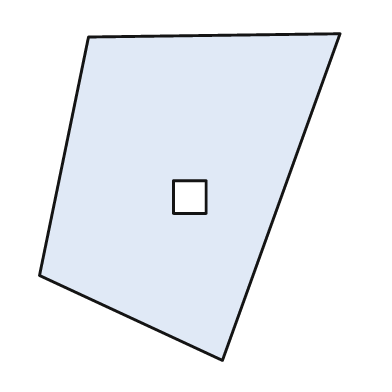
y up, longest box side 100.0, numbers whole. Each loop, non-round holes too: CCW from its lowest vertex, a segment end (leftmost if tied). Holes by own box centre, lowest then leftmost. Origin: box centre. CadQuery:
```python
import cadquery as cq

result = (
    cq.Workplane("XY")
    .moveTo(10.0, -50.0)
    .lineTo(46.0, 50.0)
    .lineTo(-31.0, 49.0)
    .lineTo(-46.0, -24.0)
    .close()
    .moveTo(-5.0, -5.0)
    .lineTo(5.0, -5.0)
    .lineTo(5.0, 5.0)
    .lineTo(-5.0, 5.0)
    .close()
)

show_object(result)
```